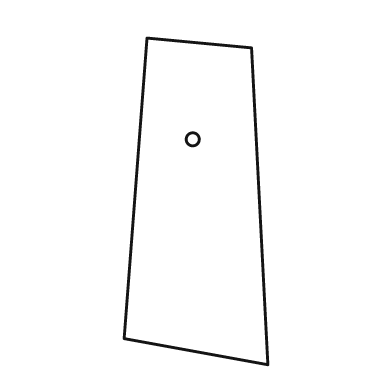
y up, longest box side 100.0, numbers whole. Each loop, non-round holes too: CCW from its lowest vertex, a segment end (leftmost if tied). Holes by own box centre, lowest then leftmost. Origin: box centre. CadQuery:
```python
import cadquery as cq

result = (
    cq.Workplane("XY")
    .moveTo(22.0, -50.0)
    .lineTo(17.0, 47.0)
    .lineTo(-15.0, 50.0)
    .lineTo(-22.0, -42.0)
    .close()
    .moveTo(-1.0, 19.0)
    .circle(2.0)
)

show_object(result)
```